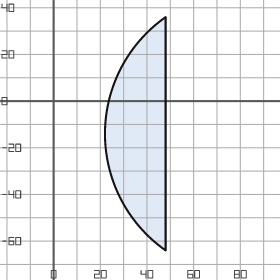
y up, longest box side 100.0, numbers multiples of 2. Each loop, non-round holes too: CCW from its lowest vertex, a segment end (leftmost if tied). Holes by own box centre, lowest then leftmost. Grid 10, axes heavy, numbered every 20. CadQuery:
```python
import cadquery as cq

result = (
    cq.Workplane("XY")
    .moveTo(48.0, -64.0)
    .lineTo(48.0, 36.0)
    .threePointArc((22.0, -14.0), (48.0, -64.0))
    .close()
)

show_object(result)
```